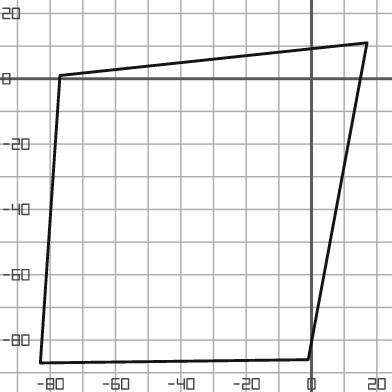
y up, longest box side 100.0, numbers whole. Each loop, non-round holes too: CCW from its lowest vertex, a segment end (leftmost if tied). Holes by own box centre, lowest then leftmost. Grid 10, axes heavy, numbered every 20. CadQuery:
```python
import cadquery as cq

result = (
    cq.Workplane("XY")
    .moveTo(-83.0, -87.0)
    .lineTo(-1.0, -86.0)
    .lineTo(17.0, 11.0)
    .lineTo(-77.0, 1.0)
    .close()
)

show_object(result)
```